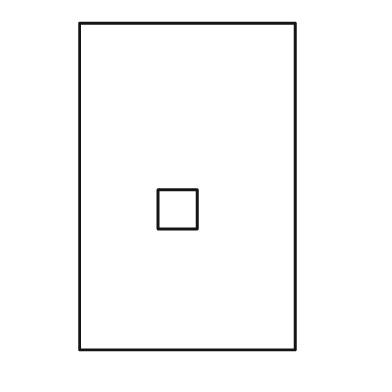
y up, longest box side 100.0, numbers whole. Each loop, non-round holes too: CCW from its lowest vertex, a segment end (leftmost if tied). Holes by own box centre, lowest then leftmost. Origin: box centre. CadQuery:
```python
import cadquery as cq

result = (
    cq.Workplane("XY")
    .moveTo(-33.0, -50.0)
    .lineTo(33.0, -50.0)
    .lineTo(33.0, 50.0)
    .lineTo(-33.0, 50.0)
    .close()
    .moveTo(-9.0, -13.0)
    .lineTo(3.0, -13.0)
    .lineTo(3.0, -1.0)
    .lineTo(-9.0, -1.0)
    .close()
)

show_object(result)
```